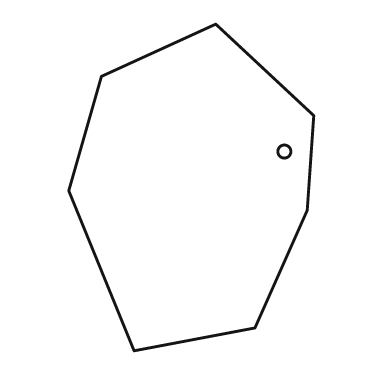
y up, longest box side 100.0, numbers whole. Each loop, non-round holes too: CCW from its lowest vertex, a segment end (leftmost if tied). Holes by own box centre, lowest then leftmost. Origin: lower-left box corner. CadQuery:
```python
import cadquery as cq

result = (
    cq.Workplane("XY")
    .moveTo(20.0, 0.0)
    .lineTo(57.0, 7.0)
    .lineTo(73.0, 43.0)
    .lineTo(75.0, 72.0)
    .lineTo(45.0, 100.0)
    .lineTo(10.0, 84.0)
    .lineTo(0.0, 49.0)
    .close()
    .moveTo(66.0, 61.0)
    .circle(2.0)
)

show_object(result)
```